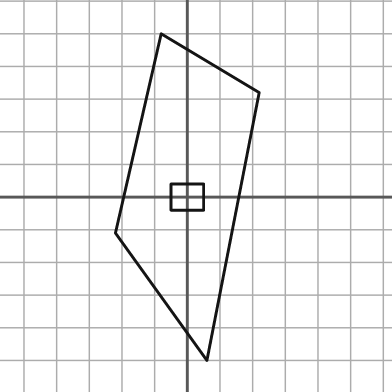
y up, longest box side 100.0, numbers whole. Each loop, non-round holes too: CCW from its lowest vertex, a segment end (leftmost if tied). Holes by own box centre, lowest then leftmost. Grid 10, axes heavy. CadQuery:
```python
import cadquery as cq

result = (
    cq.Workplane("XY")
    .moveTo(6.0, -50.0)
    .lineTo(22.0, 32.0)
    .lineTo(-8.0, 50.0)
    .lineTo(-22.0, -11.0)
    .close()
    .moveTo(-5.0, -4.0)
    .lineTo(5.0, -4.0)
    .lineTo(5.0, 4.0)
    .lineTo(-5.0, 4.0)
    .close()
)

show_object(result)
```